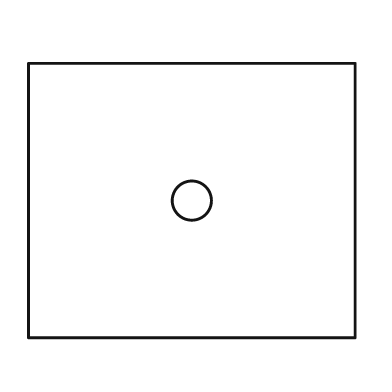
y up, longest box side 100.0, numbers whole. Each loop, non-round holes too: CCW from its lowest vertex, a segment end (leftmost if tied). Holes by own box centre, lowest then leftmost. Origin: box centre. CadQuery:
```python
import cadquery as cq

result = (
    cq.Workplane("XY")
    .moveTo(-50.0, -42.0)
    .lineTo(50.0, -42.0)
    .lineTo(50.0, 42.0)
    .lineTo(-50.0, 42.0)
    .close()
    .moveTo(0.0, 0.0)
    .circle(6.0)
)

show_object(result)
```